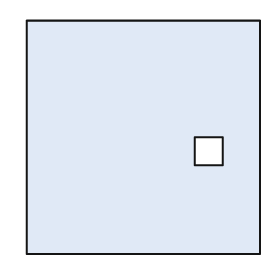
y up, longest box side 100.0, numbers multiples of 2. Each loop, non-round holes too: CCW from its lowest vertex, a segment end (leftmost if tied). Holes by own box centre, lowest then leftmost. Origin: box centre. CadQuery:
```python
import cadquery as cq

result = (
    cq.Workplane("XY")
    .moveTo(-50.0, -50.0)
    .lineTo(50.0, -50.0)
    .lineTo(50.0, 50.0)
    .lineTo(-50.0, 50.0)
    .close()
    .moveTo(22.0, -12.0)
    .lineTo(34.0, -12.0)
    .lineTo(34.0, 0.0)
    .lineTo(22.0, 0.0)
    .close()
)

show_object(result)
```